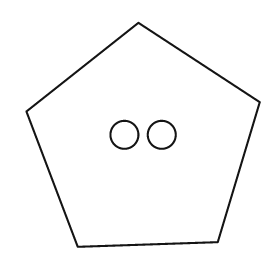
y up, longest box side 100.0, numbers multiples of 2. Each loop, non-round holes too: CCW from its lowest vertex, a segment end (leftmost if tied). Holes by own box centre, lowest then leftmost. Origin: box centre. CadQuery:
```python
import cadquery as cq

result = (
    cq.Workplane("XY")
    .moveTo(-28.0, -48.0)
    .lineTo(32.0, -46.0)
    .lineTo(50.0, 14.0)
    .lineTo(-2.0, 48.0)
    .lineTo(-50.0, 10.0)
    .close()
    .moveTo(-8.0, 0.0)
    .circle(6.0)
    .moveTo(8.0, 0.0)
    .circle(6.0)
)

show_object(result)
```